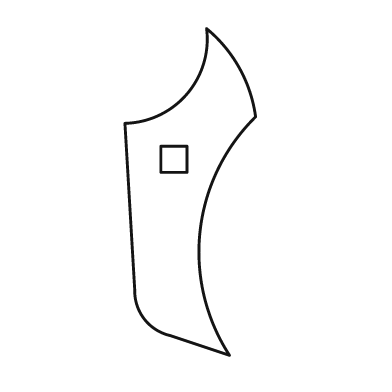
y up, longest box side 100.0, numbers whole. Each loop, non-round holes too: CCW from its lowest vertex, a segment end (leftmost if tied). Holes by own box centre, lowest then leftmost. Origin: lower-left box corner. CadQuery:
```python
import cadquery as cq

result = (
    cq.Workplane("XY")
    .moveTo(32.0, 0.0)
    .threePointArc((23.0, 38.0), (40.0, 73.0))
    .threePointArc((35.0, 88.0), (25.0, 100.0))
    .threePointArc((19.0, 80.0), (0.0, 71.0))
    .lineTo(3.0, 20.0)
    .threePointArc((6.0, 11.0), (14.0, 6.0))
    .close()
    .moveTo(11.0, 56.0)
    .lineTo(19.0, 56.0)
    .lineTo(19.0, 64.0)
    .lineTo(11.0, 64.0)
    .close()
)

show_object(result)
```